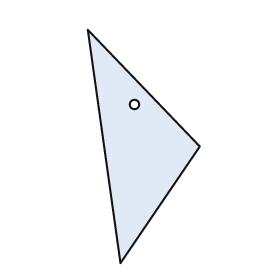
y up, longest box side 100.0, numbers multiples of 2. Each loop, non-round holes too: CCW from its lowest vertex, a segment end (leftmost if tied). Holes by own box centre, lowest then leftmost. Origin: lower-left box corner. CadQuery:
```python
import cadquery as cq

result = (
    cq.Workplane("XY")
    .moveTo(14.0, 0.0)
    .lineTo(48.0, 50.0)
    .lineTo(0.0, 100.0)
    .close()
    .moveTo(20.0, 68.0)
    .circle(2.0)
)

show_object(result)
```